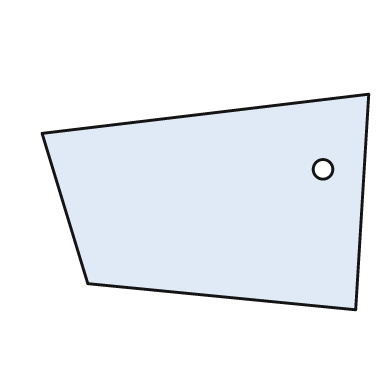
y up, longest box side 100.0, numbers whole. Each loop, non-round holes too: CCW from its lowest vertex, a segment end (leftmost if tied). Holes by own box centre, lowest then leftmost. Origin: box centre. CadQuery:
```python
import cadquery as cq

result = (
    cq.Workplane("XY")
    .moveTo(46.0, -33.0)
    .lineTo(50.0, 33.0)
    .lineTo(-50.0, 21.0)
    .lineTo(-36.0, -25.0)
    .close()
    .moveTo(36.0, 10.0)
    .circle(3.0)
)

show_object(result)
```